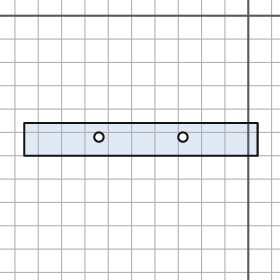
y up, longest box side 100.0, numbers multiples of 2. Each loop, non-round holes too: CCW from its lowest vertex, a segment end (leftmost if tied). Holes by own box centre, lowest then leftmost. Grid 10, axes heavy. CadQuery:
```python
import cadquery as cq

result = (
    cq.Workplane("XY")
    .moveTo(-96.0, -60.0)
    .lineTo(4.0, -60.0)
    .lineTo(4.0, -46.0)
    .lineTo(-96.0, -46.0)
    .close()
    .moveTo(-64.0, -52.0)
    .circle(2.0)
    .moveTo(-28.0, -52.0)
    .circle(2.0)
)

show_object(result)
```